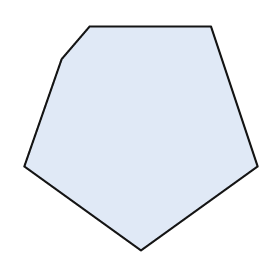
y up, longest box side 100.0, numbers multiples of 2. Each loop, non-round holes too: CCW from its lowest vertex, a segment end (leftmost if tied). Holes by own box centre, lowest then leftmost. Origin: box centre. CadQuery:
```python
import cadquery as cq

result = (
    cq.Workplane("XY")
    .moveTo(0.0, -48.0)
    .lineTo(50.0, -12.0)
    .lineTo(30.0, 48.0)
    .lineTo(-22.0, 48.0)
    .lineTo(-34.0, 34.0)
    .lineTo(-50.0, -12.0)
    .close()
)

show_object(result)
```